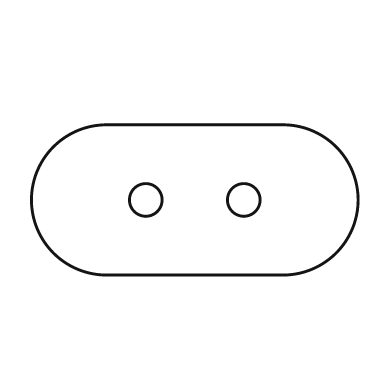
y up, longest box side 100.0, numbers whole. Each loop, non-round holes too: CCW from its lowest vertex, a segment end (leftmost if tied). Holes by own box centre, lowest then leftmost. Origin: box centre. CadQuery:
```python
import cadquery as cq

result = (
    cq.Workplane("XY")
    .moveTo(-27.0, -23.0)
    .lineTo(27.0, -23.0)
    .threePointArc((50.0, 0.0), (27.0, 23.0))
    .lineTo(-27.0, 23.0)
    .threePointArc((-50.0, 0.0), (-27.0, -23.0))
    .close()
    .moveTo(-15.0, 0.0)
    .circle(5.0)
    .moveTo(15.0, 0.0)
    .circle(5.0)
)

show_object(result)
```